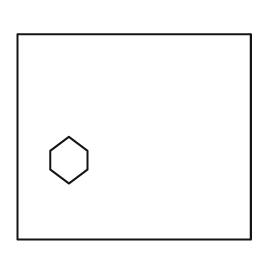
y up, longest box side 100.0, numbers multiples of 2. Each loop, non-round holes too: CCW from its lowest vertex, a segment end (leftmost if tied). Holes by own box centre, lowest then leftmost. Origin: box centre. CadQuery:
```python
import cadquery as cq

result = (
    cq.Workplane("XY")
    .moveTo(-50.0, -44.0)
    .lineTo(50.0, -44.0)
    .lineTo(50.0, 44.0)
    .lineTo(-50.0, 44.0)
    .close()
    .moveTo(-28.0, -20.0)
    .lineTo(-20.0, -14.0)
    .lineTo(-20.0, -6.0)
    .lineTo(-28.0, 0.0)
    .lineTo(-36.0, -6.0)
    .lineTo(-36.0, -14.0)
    .close()
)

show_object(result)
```